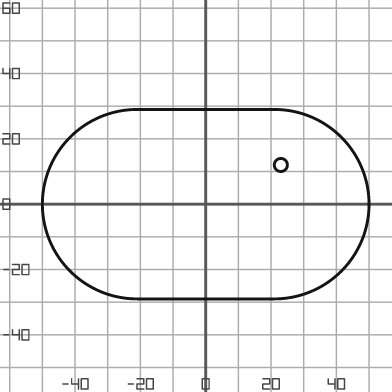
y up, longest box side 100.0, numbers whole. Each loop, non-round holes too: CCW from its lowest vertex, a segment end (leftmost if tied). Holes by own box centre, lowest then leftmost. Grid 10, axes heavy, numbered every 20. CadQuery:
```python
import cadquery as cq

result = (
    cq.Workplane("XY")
    .moveTo(-21.0, -29.0)
    .lineTo(21.0, -29.0)
    .threePointArc((50.0, 0.0), (21.0, 29.0))
    .lineTo(-21.0, 29.0)
    .threePointArc((-50.0, 0.0), (-21.0, -29.0))
    .close()
    .moveTo(23.0, 12.0)
    .circle(2.0)
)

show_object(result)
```